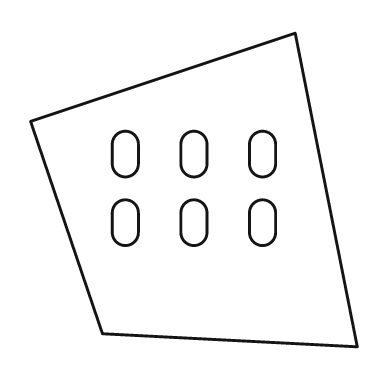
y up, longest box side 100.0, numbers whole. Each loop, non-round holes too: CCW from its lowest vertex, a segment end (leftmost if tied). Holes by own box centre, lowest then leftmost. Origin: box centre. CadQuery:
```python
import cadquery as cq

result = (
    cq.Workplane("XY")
    .moveTo(50.0, -48.0)
    .lineTo(31.0, 48.0)
    .lineTo(-50.0, 21.0)
    .lineTo(-28.0, -44.0)
    .close()
    .moveTo(-25.0, -13.0)
    .threePointArc((-21.0, -17.0), (-17.0, -13.0))
    .lineTo(-17.0, -7.0)
    .threePointArc((-21.0, -3.0), (-25.0, -7.0))
    .close()
    .moveTo(-4.0, -13.0)
    .threePointArc((0.0, -17.0), (4.0, -13.0))
    .lineTo(4.0, -7.0)
    .threePointArc((0.0, -3.0), (-4.0, -7.0))
    .close()
    .moveTo(17.0, -13.0)
    .threePointArc((21.0, -17.0), (25.0, -13.0))
    .lineTo(25.0, -7.0)
    .threePointArc((21.0, -3.0), (17.0, -7.0))
    .close()
    .moveTo(-25.0, 8.0)
    .threePointArc((-21.0, 4.0), (-17.0, 8.0))
    .lineTo(-17.0, 14.0)
    .threePointArc((-21.0, 18.0), (-25.0, 14.0))
    .close()
    .moveTo(-4.0, 8.0)
    .threePointArc((0.0, 4.0), (4.0, 8.0))
    .lineTo(4.0, 14.0)
    .threePointArc((0.0, 18.0), (-4.0, 14.0))
    .close()
    .moveTo(17.0, 8.0)
    .threePointArc((21.0, 4.0), (25.0, 8.0))
    .lineTo(25.0, 14.0)
    .threePointArc((21.0, 18.0), (17.0, 14.0))
    .close()
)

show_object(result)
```